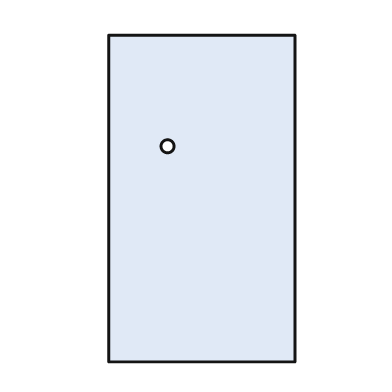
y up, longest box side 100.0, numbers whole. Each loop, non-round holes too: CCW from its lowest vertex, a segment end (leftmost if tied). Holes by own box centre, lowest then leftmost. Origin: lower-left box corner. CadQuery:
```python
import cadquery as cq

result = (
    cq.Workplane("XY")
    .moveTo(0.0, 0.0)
    .lineTo(57.0, 0.0)
    .lineTo(57.0, 100.0)
    .lineTo(0.0, 100.0)
    .close()
    .moveTo(18.0, 66.0)
    .circle(2.0)
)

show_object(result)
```